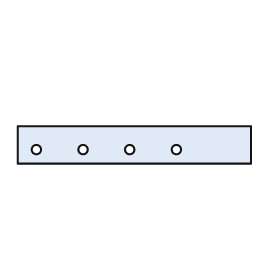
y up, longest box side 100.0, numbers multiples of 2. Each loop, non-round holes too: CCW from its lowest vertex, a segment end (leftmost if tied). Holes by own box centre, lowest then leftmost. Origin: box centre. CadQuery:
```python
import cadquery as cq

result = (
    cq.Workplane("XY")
    .moveTo(-50.0, -8.0)
    .lineTo(50.0, -8.0)
    .lineTo(50.0, 8.0)
    .lineTo(-50.0, 8.0)
    .close()
    .moveTo(-42.0, -2.0)
    .circle(2.0)
    .moveTo(-22.0, -2.0)
    .circle(2.0)
    .moveTo(-2.0, -2.0)
    .circle(2.0)
    .moveTo(18.0, -2.0)
    .circle(2.0)
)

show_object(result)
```